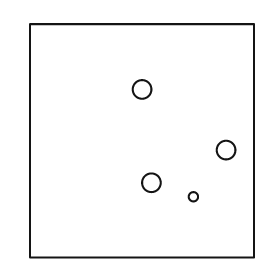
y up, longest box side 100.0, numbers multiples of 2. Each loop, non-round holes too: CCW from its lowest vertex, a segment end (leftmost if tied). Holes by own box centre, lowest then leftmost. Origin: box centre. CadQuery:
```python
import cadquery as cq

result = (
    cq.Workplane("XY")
    .moveTo(-48.0, -50.0)
    .lineTo(48.0, -50.0)
    .lineTo(48.0, 50.0)
    .lineTo(-48.0, 50.0)
    .close()
    .moveTo(22.0, -24.0)
    .circle(2.0)
    .moveTo(4.0, -18.0)
    .circle(4.0)
    .moveTo(36.0, -4.0)
    .circle(4.0)
    .moveTo(0.0, 22.0)
    .circle(4.0)
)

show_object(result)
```